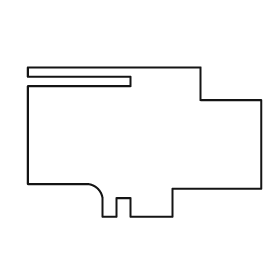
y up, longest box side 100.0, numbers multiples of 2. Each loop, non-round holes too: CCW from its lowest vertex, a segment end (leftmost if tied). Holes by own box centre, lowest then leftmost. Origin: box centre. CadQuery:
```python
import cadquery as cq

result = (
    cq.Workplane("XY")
    .moveTo(-18.0, -32.0)
    .lineTo(-12.0, -32.0)
    .lineTo(-12.0, -24.0)
    .lineTo(-6.0, -24.0)
    .lineTo(-6.0, -32.0)
    .lineTo(12.0, -32.0)
    .lineTo(12.0, -20.0)
    .lineTo(50.0, -20.0)
    .lineTo(50.0, 18.0)
    .lineTo(24.0, 18.0)
    .lineTo(24.0, 32.0)
    .lineTo(-50.0, 32.0)
    .lineTo(-50.0, 28.0)
    .lineTo(-6.0, 28.0)
    .lineTo(-6.0, 24.0)
    .lineTo(-50.0, 24.0)
    .lineTo(-50.0, -18.0)
    .lineTo(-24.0, -18.0)
    .threePointArc((-20.0, -20.0), (-18.0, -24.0))
    .close()
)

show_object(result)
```